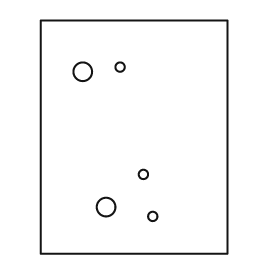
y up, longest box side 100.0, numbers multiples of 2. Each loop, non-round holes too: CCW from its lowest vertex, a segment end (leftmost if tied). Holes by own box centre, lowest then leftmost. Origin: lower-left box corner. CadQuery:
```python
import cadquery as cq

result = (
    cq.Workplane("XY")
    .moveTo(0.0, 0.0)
    .lineTo(80.0, 0.0)
    .lineTo(80.0, 100.0)
    .lineTo(0.0, 100.0)
    .close()
    .moveTo(48.0, 16.0)
    .circle(2.0)
    .moveTo(28.0, 20.0)
    .circle(4.0)
    .moveTo(44.0, 34.0)
    .circle(2.0)
    .moveTo(18.0, 78.0)
    .circle(4.0)
    .moveTo(34.0, 80.0)
    .circle(2.0)
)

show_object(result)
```